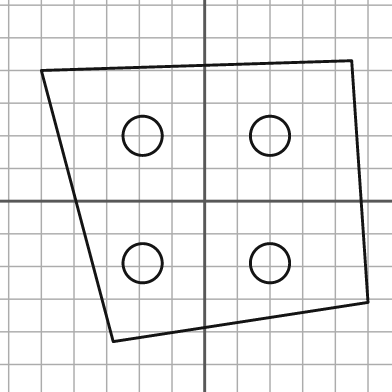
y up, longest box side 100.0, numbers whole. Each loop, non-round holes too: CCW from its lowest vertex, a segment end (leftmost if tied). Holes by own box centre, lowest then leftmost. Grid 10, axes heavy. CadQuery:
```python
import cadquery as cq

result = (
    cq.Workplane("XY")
    .moveTo(-28.0, -43.0)
    .lineTo(50.0, -31.0)
    .lineTo(45.0, 43.0)
    .lineTo(-50.0, 40.0)
    .close()
    .moveTo(-19.0, -19.0)
    .circle(6.0)
    .moveTo(20.0, -19.0)
    .circle(6.0)
    .moveTo(-19.0, 20.0)
    .circle(6.0)
    .moveTo(20.0, 20.0)
    .circle(6.0)
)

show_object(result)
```